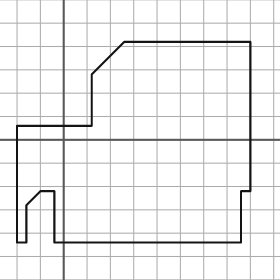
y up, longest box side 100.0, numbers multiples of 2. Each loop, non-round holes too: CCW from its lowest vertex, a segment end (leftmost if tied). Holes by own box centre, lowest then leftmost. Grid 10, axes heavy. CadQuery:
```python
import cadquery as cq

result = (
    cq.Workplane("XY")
    .moveTo(-20.0, -44.0)
    .lineTo(-16.0, -44.0)
    .lineTo(-16.0, -28.0)
    .lineTo(-10.0, -22.0)
    .lineTo(-4.0, -22.0)
    .lineTo(-4.0, -44.0)
    .lineTo(76.0, -44.0)
    .lineTo(76.0, -22.0)
    .lineTo(80.0, -22.0)
    .lineTo(80.0, 42.0)
    .lineTo(26.0, 42.0)
    .lineTo(12.0, 28.0)
    .lineTo(12.0, 6.0)
    .lineTo(-20.0, 6.0)
    .close()
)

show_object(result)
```